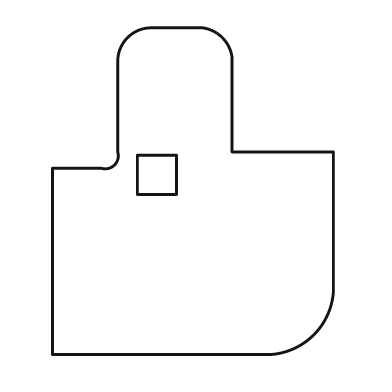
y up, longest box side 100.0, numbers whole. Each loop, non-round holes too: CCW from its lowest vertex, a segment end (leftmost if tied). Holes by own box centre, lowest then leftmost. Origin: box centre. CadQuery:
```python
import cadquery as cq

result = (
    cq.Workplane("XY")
    .moveTo(-43.0, -50.0)
    .lineTo(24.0, -50.0)
    .threePointArc((37.0, -44.0), (43.0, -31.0))
    .lineTo(43.0, 12.0)
    .lineTo(12.0, 12.0)
    .lineTo(12.0, 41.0)
    .threePointArc((9.0, 47.0), (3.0, 50.0))
    .lineTo(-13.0, 50.0)
    .threePointArc((-20.0, 47.0), (-23.0, 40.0))
    .lineTo(-23.0, 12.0)
    .threePointArc((-24.0, 8.0), (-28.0, 7.0))
    .lineTo(-43.0, 7.0)
    .close()
    .moveTo(-17.0, -1.0)
    .lineTo(-5.0, -1.0)
    .lineTo(-5.0, 11.0)
    .lineTo(-17.0, 11.0)
    .close()
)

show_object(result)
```